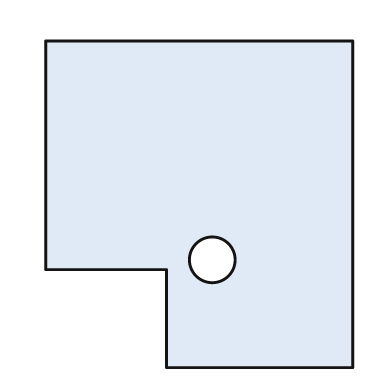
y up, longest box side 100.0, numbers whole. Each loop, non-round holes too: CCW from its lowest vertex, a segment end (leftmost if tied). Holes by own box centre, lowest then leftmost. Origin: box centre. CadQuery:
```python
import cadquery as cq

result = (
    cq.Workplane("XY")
    .moveTo(-10.0, -50.0)
    .lineTo(47.0, -50.0)
    .lineTo(47.0, 50.0)
    .lineTo(-47.0, 50.0)
    .lineTo(-47.0, -20.0)
    .lineTo(-10.0, -20.0)
    .close()
    .moveTo(4.0, -17.0)
    .circle(7.0)
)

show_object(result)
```